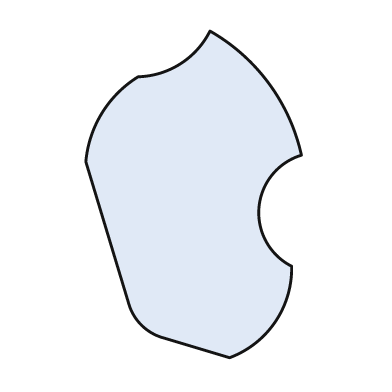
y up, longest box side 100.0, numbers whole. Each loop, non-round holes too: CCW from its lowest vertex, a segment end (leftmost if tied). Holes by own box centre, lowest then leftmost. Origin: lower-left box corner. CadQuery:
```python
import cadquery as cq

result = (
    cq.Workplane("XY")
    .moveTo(44.0, 0.0)
    .threePointArc((58.0, 11.0), (63.0, 28.0))
    .threePointArc((53.0, 46.0), (66.0, 62.0))
    .threePointArc((56.0, 84.0), (38.0, 100.0))
    .threePointArc((29.0, 90.0), (16.0, 86.0))
    .threePointArc((5.0, 75.0), (0.0, 60.0))
    .lineTo(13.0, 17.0)
    .threePointArc((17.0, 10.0), (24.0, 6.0))
    .close()
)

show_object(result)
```